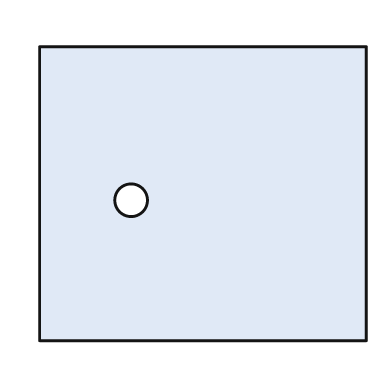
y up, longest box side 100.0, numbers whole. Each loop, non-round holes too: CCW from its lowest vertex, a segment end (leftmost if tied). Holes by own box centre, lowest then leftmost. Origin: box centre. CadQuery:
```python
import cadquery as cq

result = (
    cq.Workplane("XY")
    .moveTo(-50.0, -45.0)
    .lineTo(50.0, -45.0)
    .lineTo(50.0, 45.0)
    .lineTo(-50.0, 45.0)
    .close()
    .moveTo(-22.0, -2.0)
    .circle(5.0)
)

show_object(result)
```